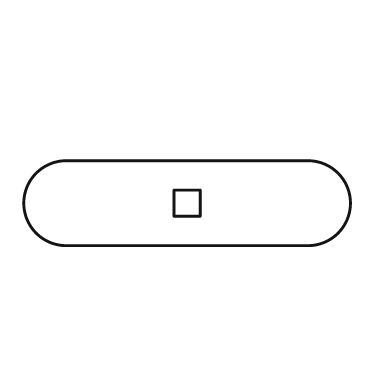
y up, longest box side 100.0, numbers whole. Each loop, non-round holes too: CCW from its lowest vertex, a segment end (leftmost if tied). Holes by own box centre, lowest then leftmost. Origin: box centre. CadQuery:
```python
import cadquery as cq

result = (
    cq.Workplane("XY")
    .moveTo(-37.0, -13.0)
    .lineTo(37.0, -13.0)
    .threePointArc((50.0, 0.0), (37.0, 13.0))
    .lineTo(-37.0, 13.0)
    .threePointArc((-50.0, 0.0), (-37.0, -13.0))
    .close()
    .moveTo(-4.0, -4.0)
    .lineTo(4.0, -4.0)
    .lineTo(4.0, 4.0)
    .lineTo(-4.0, 4.0)
    .close()
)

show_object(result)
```